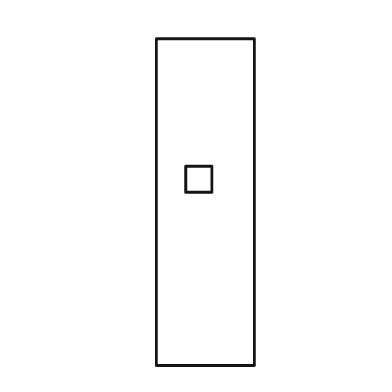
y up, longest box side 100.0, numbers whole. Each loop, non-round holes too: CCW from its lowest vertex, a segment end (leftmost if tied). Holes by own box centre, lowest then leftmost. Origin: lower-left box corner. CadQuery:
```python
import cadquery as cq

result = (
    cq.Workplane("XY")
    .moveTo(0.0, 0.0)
    .lineTo(30.0, 0.0)
    .lineTo(30.0, 100.0)
    .lineTo(0.0, 100.0)
    .close()
    .moveTo(9.0, 53.0)
    .lineTo(17.0, 53.0)
    .lineTo(17.0, 61.0)
    .lineTo(9.0, 61.0)
    .close()
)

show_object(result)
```